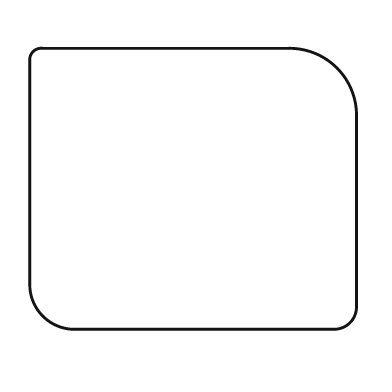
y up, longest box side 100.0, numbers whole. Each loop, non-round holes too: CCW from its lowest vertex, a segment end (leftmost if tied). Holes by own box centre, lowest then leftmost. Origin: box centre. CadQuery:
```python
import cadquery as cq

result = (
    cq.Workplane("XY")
    .moveTo(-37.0, -43.0)
    .lineTo(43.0, -43.0)
    .threePointArc((48.0, -41.0), (50.0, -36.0))
    .lineTo(50.0, 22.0)
    .threePointArc((44.0, 37.0), (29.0, 43.0))
    .lineTo(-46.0, 43.0)
    .threePointArc((-49.0, 42.0), (-50.0, 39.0))
    .lineTo(-50.0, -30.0)
    .threePointArc((-46.0, -39.0), (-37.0, -43.0))
    .close()
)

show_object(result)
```